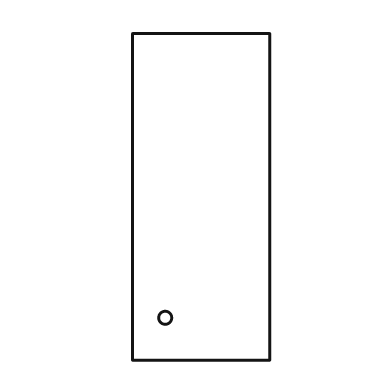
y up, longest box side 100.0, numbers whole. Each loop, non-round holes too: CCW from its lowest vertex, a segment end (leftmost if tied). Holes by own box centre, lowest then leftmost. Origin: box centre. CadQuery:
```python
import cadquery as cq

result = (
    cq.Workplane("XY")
    .moveTo(-21.0, -50.0)
    .lineTo(21.0, -50.0)
    .lineTo(21.0, 50.0)
    .lineTo(-21.0, 50.0)
    .close()
    .moveTo(-11.0, -37.0)
    .circle(2.0)
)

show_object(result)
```